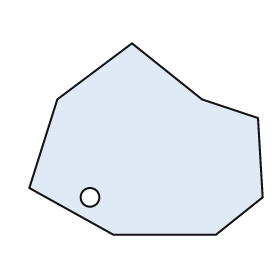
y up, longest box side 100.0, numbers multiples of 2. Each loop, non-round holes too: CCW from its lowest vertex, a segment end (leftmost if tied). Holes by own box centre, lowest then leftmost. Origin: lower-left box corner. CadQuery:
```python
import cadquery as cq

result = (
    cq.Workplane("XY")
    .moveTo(36.0, 0.0)
    .lineTo(80.0, 0.0)
    .lineTo(100.0, 16.0)
    .lineTo(98.0, 50.0)
    .lineTo(74.0, 58.0)
    .lineTo(44.0, 82.0)
    .lineTo(12.0, 58.0)
    .lineTo(0.0, 20.0)
    .close()
    .moveTo(26.0, 16.0)
    .circle(4.0)
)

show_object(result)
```